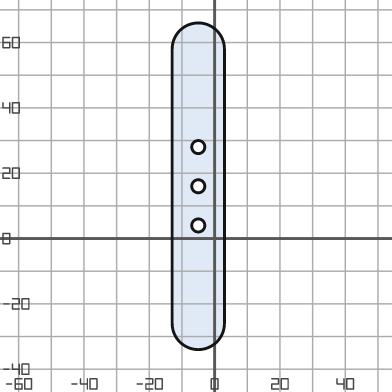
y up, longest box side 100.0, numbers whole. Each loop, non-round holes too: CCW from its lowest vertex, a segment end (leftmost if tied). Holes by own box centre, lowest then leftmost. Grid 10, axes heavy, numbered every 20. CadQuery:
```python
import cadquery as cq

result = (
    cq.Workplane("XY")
    .moveTo(-13.0, -26.0)
    .threePointArc((-5.0, -34.0), (3.0, -26.0))
    .lineTo(3.0, 58.0)
    .threePointArc((-5.0, 66.0), (-13.0, 58.0))
    .close()
    .moveTo(-5.0, 4.0)
    .circle(2.0)
    .moveTo(-5.0, 16.0)
    .circle(2.0)
    .moveTo(-5.0, 28.0)
    .circle(2.0)
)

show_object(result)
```